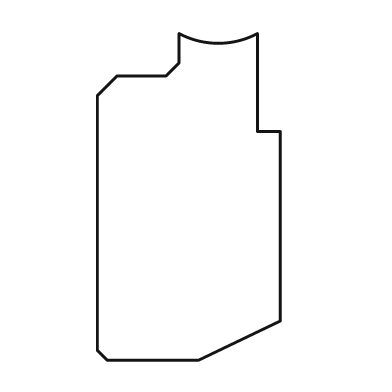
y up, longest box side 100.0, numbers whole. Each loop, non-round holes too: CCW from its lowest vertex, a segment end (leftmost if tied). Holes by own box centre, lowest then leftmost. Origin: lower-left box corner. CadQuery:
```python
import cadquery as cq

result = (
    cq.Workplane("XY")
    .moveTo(3.0, 0.0)
    .lineTo(31.0, 0.0)
    .lineTo(56.0, 12.0)
    .lineTo(56.0, 70.0)
    .lineTo(49.0, 70.0)
    .lineTo(49.0, 100.0)
    .threePointArc((37.0, 97.0), (25.0, 100.0))
    .lineTo(25.0, 91.0)
    .lineTo(21.0, 87.0)
    .lineTo(6.0, 87.0)
    .lineTo(0.0, 81.0)
    .lineTo(0.0, 3.0)
    .close()
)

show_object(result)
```